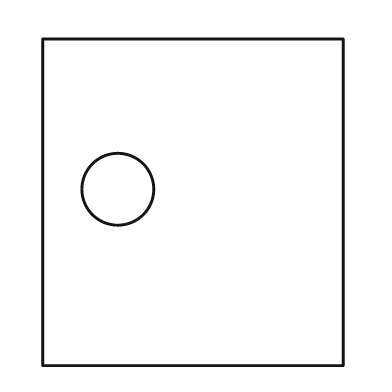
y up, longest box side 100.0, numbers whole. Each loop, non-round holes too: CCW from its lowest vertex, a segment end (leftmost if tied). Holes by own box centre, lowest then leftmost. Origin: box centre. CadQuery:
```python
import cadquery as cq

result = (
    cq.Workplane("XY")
    .moveTo(-46.0, -50.0)
    .lineTo(46.0, -50.0)
    .lineTo(46.0, 50.0)
    .lineTo(-46.0, 50.0)
    .close()
    .moveTo(-23.0, 4.0)
    .circle(11.0)
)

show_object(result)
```